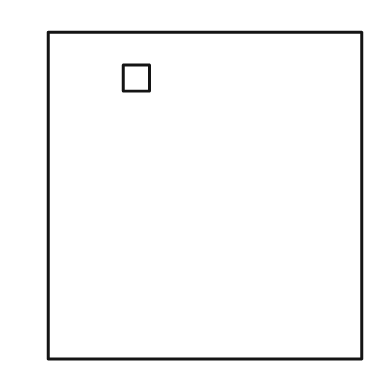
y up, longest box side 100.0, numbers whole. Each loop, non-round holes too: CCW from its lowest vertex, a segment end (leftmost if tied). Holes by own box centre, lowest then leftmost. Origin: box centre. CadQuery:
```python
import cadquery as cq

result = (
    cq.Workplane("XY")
    .moveTo(-48.0, -50.0)
    .lineTo(48.0, -50.0)
    .lineTo(48.0, 50.0)
    .lineTo(-48.0, 50.0)
    .close()
    .moveTo(-25.0, 32.0)
    .lineTo(-17.0, 32.0)
    .lineTo(-17.0, 40.0)
    .lineTo(-25.0, 40.0)
    .close()
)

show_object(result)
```